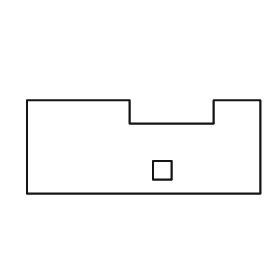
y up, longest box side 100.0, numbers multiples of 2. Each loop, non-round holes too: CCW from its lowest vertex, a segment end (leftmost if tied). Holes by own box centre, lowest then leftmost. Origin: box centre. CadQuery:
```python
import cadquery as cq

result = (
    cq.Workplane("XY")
    .moveTo(-50.0, -20.0)
    .lineTo(50.0, -20.0)
    .lineTo(50.0, 20.0)
    .lineTo(30.0, 20.0)
    .lineTo(30.0, 10.0)
    .lineTo(-6.0, 10.0)
    .lineTo(-6.0, 20.0)
    .lineTo(-50.0, 20.0)
    .close()
    .moveTo(4.0, -14.0)
    .lineTo(12.0, -14.0)
    .lineTo(12.0, -6.0)
    .lineTo(4.0, -6.0)
    .close()
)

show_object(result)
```